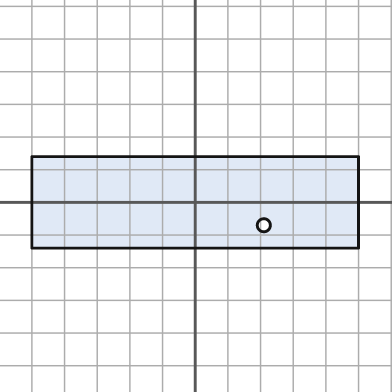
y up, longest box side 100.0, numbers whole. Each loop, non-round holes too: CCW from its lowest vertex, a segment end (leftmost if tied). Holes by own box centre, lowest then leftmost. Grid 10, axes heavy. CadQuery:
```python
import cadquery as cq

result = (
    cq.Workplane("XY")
    .moveTo(-50.0, -14.0)
    .lineTo(50.0, -14.0)
    .lineTo(50.0, 14.0)
    .lineTo(-50.0, 14.0)
    .close()
    .moveTo(21.0, -7.0)
    .circle(2.0)
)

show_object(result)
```